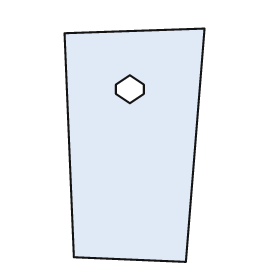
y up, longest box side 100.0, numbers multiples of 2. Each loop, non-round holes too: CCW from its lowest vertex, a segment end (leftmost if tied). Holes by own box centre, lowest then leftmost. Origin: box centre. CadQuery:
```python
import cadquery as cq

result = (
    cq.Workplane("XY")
    .moveTo(22.0, -50.0)
    .lineTo(30.0, 50.0)
    .lineTo(-30.0, 48.0)
    .lineTo(-26.0, -48.0)
    .close()
    .moveTo(-2.0, 18.0)
    .lineTo(4.0, 22.0)
    .lineTo(4.0, 26.0)
    .lineTo(-2.0, 30.0)
    .lineTo(-8.0, 26.0)
    .lineTo(-8.0, 22.0)
    .close()
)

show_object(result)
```